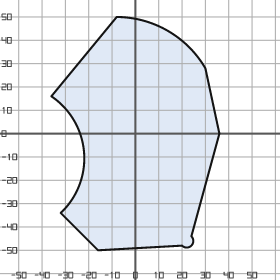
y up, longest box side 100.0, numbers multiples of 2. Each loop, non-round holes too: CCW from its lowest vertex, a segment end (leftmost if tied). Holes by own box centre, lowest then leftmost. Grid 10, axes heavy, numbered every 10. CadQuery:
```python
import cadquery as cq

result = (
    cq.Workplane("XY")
    .moveTo(-16.0, -50.0)
    .lineTo(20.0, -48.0)
    .threePointArc((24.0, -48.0), (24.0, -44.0))
    .lineTo(36.0, 0.0)
    .lineTo(30.0, 28.0)
    .threePointArc((14.0, 44.0), (-8.0, 50.0))
    .lineTo(-36.0, 16.0)
    .threePointArc((-22.0, -8.0), (-32.0, -34.0))
    .close()
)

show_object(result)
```